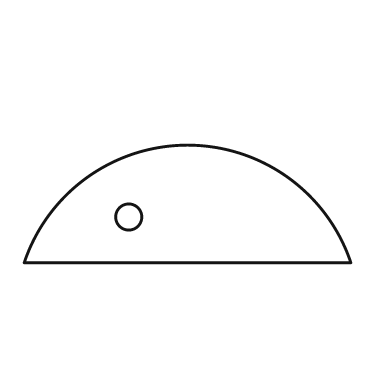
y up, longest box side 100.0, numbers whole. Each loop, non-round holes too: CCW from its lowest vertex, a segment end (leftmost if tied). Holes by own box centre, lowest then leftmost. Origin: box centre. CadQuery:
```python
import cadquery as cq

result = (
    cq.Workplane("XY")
    .moveTo(-50.0, -18.0)
    .lineTo(50.0, -18.0)
    .threePointArc((0.0, 18.0), (-50.0, -18.0))
    .close()
    .moveTo(-18.0, -4.0)
    .circle(4.0)
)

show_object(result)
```